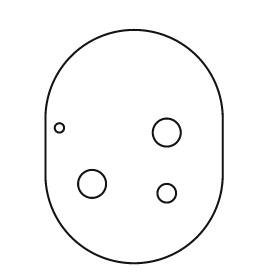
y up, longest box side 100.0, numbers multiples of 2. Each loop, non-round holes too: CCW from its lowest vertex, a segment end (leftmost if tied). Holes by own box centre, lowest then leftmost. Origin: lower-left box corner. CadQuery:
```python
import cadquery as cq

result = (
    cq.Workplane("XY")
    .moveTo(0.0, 38.0)
    .threePointArc((38.0, 0.0), (76.0, 38.0))
    .lineTo(76.0, 62.0)
    .threePointArc((38.0, 100.0), (0.0, 62.0))
    .close()
    .moveTo(52.0, 30.0)
    .circle(4.0)
    .moveTo(20.0, 34.0)
    .circle(6.0)
    .moveTo(52.0, 56.0)
    .circle(6.0)
    .moveTo(6.0, 58.0)
    .circle(2.0)
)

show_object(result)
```